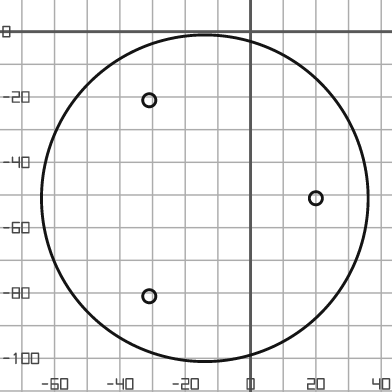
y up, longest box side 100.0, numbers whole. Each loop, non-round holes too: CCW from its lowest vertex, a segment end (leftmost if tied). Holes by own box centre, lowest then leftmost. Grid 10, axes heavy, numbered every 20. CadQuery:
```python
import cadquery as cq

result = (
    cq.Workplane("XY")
    .moveTo(-14.0, -51.0)
    .circle(50.0)
    .moveTo(-31.0, -81.0)
    .circle(2.0)
    .moveTo(20.0, -51.0)
    .circle(2.0)
    .moveTo(-31.0, -21.0)
    .circle(2.0)
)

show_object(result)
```